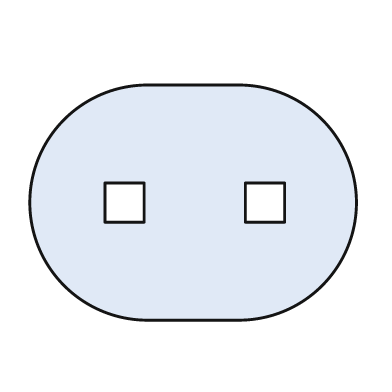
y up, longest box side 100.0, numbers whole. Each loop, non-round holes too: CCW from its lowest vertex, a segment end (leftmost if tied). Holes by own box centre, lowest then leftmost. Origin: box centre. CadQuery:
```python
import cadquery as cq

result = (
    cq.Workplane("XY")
    .moveTo(-14.0, -36.0)
    .lineTo(14.0, -36.0)
    .threePointArc((50.0, 0.0), (14.0, 36.0))
    .lineTo(-14.0, 36.0)
    .threePointArc((-50.0, 0.0), (-14.0, -36.0))
    .close()
    .moveTo(-27.0, -6.0)
    .lineTo(-15.0, -6.0)
    .lineTo(-15.0, 6.0)
    .lineTo(-27.0, 6.0)
    .close()
    .moveTo(16.0, -6.0)
    .lineTo(28.0, -6.0)
    .lineTo(28.0, 6.0)
    .lineTo(16.0, 6.0)
    .close()
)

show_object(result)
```